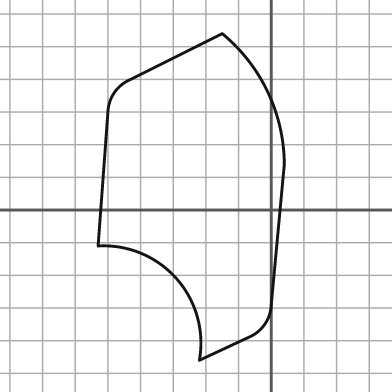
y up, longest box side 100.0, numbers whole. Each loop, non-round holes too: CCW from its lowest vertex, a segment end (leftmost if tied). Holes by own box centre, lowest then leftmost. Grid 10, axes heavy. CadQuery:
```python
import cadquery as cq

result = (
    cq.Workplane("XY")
    .moveTo(-22.0, -46.0)
    .lineTo(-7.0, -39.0)
    .threePointArc((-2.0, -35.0), (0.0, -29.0))
    .lineTo(4.0, 14.0)
    .threePointArc((-1.0, 36.0), (-15.0, 54.0))
    .lineTo(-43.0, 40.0)
    .threePointArc((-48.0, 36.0), (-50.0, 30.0))
    .lineTo(-53.0, -11.0)
    .threePointArc((-29.0, -21.0), (-22.0, -46.0))
    .close()
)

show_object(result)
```